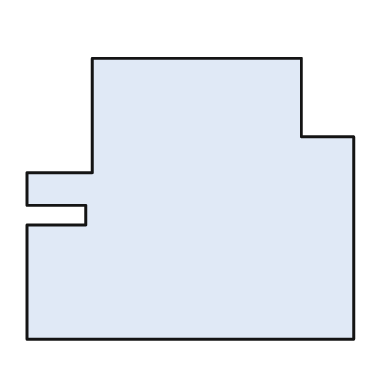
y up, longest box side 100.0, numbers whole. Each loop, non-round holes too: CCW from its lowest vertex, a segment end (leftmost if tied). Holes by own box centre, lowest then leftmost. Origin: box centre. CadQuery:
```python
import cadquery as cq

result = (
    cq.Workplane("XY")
    .moveTo(-50.0, -43.0)
    .lineTo(50.0, -43.0)
    .lineTo(50.0, 19.0)
    .lineTo(34.0, 19.0)
    .lineTo(34.0, 43.0)
    .lineTo(-30.0, 43.0)
    .lineTo(-30.0, 8.0)
    .lineTo(-50.0, 8.0)
    .lineTo(-50.0, -2.0)
    .lineTo(-32.0, -2.0)
    .lineTo(-32.0, -8.0)
    .lineTo(-50.0, -8.0)
    .close()
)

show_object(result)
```